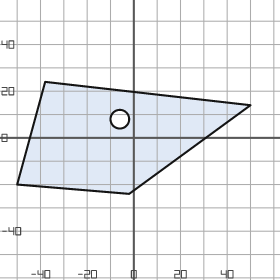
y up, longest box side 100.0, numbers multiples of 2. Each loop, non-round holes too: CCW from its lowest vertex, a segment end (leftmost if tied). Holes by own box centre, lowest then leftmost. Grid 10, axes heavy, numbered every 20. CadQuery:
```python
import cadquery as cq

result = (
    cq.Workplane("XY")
    .moveTo(-2.0, -24.0)
    .lineTo(50.0, 14.0)
    .lineTo(-38.0, 24.0)
    .lineTo(-50.0, -20.0)
    .close()
    .moveTo(-6.0, 8.0)
    .circle(4.0)
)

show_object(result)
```